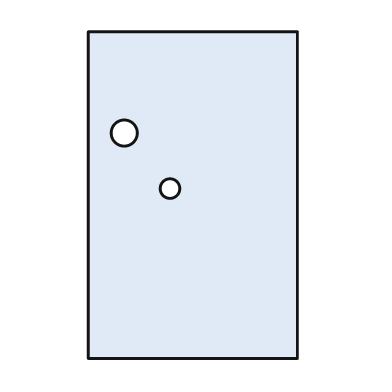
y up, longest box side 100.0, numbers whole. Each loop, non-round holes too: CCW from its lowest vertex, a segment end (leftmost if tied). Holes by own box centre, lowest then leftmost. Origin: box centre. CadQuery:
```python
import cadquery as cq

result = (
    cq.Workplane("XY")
    .moveTo(-32.0, -50.0)
    .lineTo(32.0, -50.0)
    .lineTo(32.0, 50.0)
    .lineTo(-32.0, 50.0)
    .close()
    .moveTo(-7.0, 2.0)
    .circle(3.0)
    .moveTo(-21.0, 19.0)
    .circle(4.0)
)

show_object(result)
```